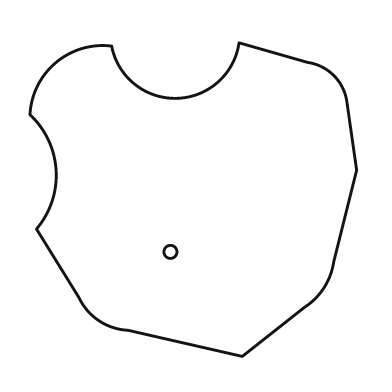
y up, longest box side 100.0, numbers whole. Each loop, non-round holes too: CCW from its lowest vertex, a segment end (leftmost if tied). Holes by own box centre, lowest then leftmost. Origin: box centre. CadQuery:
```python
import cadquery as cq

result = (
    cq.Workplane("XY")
    .moveTo(15.0, -48.0)
    .lineTo(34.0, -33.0)
    .threePointArc((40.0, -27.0), (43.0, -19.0))
    .lineTo(50.0, 9.0)
    .lineTo(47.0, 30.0)
    .threePointArc((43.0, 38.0), (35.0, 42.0))
    .lineTo(14.0, 48.0)
    .threePointArc((-5.0, 31.0), (-25.0, 47.0))
    .threePointArc((-42.0, 42.0), (-50.0, 26.0))
    .threePointArc((-42.0, 9.0), (-48.0, -9.0))
    .lineTo(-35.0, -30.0)
    .threePointArc((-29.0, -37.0), (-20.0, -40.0))
    .close()
    .moveTo(-7.0, -16.0)
    .circle(2.0)
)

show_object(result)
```